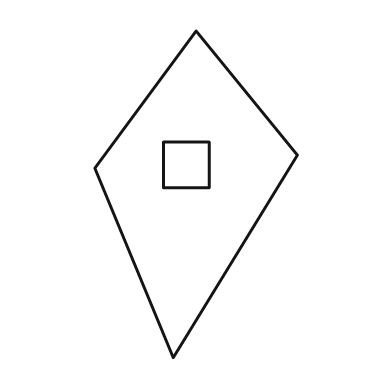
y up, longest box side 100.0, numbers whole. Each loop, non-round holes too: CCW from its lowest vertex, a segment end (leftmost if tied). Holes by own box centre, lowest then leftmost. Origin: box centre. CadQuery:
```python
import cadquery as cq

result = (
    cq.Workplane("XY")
    .moveTo(-7.0, -50.0)
    .lineTo(31.0, 12.0)
    .lineTo(0.0, 50.0)
    .lineTo(-31.0, 8.0)
    .close()
    .moveTo(-10.0, 2.0)
    .lineTo(4.0, 2.0)
    .lineTo(4.0, 16.0)
    .lineTo(-10.0, 16.0)
    .close()
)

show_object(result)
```